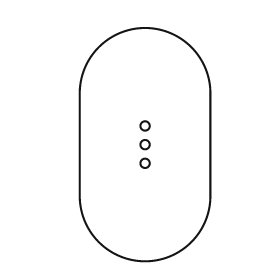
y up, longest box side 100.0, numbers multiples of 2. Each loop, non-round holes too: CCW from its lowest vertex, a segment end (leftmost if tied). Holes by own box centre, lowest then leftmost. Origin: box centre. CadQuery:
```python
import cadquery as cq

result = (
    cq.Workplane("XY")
    .moveTo(-28.0, -22.0)
    .threePointArc((0.0, -50.0), (28.0, -22.0))
    .lineTo(28.0, 22.0)
    .threePointArc((0.0, 50.0), (-28.0, 22.0))
    .close()
    .moveTo(0.0, -8.0)
    .circle(2.0)
    .moveTo(0.0, 0.0)
    .circle(2.0)
    .moveTo(0.0, 8.0)
    .circle(2.0)
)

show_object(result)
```